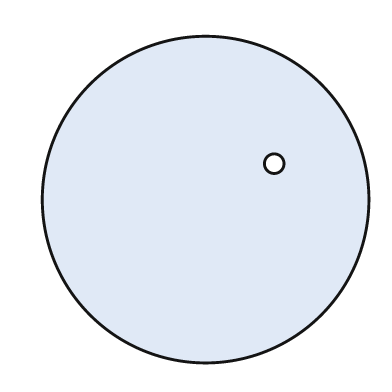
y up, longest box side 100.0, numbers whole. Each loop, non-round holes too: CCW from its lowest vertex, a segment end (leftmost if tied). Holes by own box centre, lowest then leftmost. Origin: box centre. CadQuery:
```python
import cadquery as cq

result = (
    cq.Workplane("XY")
    .moveTo(0.0, 0.0)
    .circle(50.0)
    .moveTo(21.0, 11.0)
    .circle(3.0)
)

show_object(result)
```